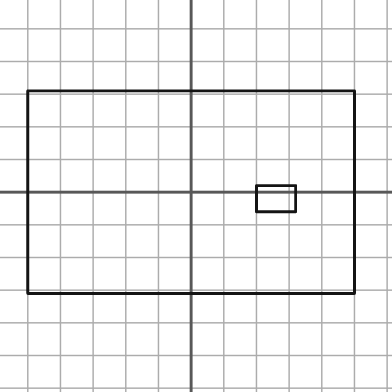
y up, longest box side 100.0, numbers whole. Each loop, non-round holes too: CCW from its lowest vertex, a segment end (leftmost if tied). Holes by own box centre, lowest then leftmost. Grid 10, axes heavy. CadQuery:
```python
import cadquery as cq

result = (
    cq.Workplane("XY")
    .moveTo(-50.0, -31.0)
    .lineTo(50.0, -31.0)
    .lineTo(50.0, 31.0)
    .lineTo(-50.0, 31.0)
    .close()
    .moveTo(20.0, -6.0)
    .lineTo(32.0, -6.0)
    .lineTo(32.0, 2.0)
    .lineTo(20.0, 2.0)
    .close()
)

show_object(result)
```